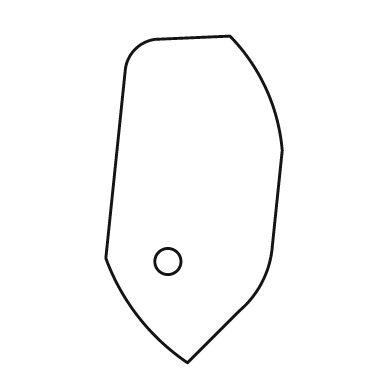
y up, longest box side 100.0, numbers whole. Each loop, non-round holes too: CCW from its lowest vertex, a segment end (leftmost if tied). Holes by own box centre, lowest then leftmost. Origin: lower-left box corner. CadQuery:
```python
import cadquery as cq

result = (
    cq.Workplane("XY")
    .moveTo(25.0, 0.0)
    .lineTo(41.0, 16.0)
    .threePointArc((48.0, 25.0), (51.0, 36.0))
    .lineTo(54.0, 65.0)
    .threePointArc((49.0, 84.0), (38.0, 100.0))
    .lineTo(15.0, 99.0)
    .threePointArc((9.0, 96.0), (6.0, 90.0))
    .lineTo(0.0, 32.0)
    .threePointArc((10.0, 14.0), (25.0, 0.0))
    .close()
    .moveTo(19.0, 31.0)
    .circle(4.0)
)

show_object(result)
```